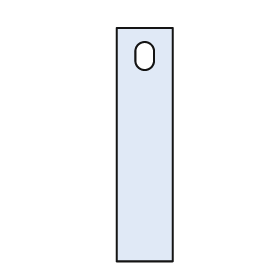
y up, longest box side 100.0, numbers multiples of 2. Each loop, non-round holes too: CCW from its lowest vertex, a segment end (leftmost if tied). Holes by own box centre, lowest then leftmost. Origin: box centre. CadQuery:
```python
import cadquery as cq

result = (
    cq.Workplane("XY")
    .moveTo(-12.0, -50.0)
    .lineTo(12.0, -50.0)
    .lineTo(12.0, 50.0)
    .lineTo(-12.0, 50.0)
    .close()
    .moveTo(-4.0, 36.0)
    .threePointArc((0.0, 32.0), (4.0, 36.0))
    .lineTo(4.0, 40.0)
    .threePointArc((0.0, 44.0), (-4.0, 40.0))
    .close()
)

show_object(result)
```